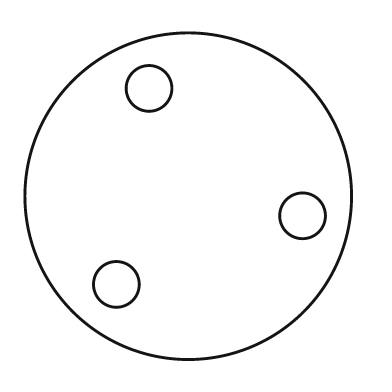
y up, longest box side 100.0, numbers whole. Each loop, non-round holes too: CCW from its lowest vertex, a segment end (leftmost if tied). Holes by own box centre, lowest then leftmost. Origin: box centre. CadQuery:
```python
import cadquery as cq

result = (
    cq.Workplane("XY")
    .moveTo(0.0, 0.0)
    .circle(50.0)
    .moveTo(-22.0, -27.0)
    .circle(7.0)
    .moveTo(35.0, -6.0)
    .circle(7.0)
    .moveTo(-12.0, 33.0)
    .circle(7.0)
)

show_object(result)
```